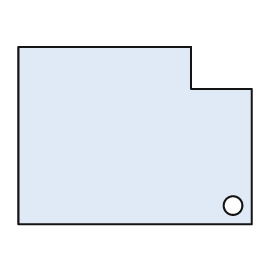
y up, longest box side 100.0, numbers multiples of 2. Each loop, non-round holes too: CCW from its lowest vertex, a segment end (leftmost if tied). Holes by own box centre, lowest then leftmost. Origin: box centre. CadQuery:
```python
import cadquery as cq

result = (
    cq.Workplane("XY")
    .moveTo(-50.0, -38.0)
    .lineTo(50.0, -38.0)
    .lineTo(50.0, 20.0)
    .lineTo(24.0, 20.0)
    .lineTo(24.0, 38.0)
    .lineTo(-50.0, 38.0)
    .close()
    .moveTo(42.0, -30.0)
    .circle(4.0)
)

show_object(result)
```